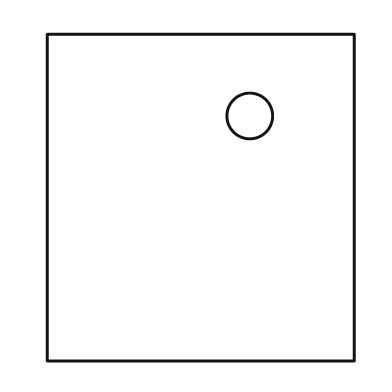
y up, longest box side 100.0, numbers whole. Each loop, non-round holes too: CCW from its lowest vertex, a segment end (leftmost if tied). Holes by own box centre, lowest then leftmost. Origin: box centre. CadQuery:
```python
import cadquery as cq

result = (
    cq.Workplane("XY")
    .moveTo(-47.0, -50.0)
    .lineTo(47.0, -50.0)
    .lineTo(47.0, 50.0)
    .lineTo(-47.0, 50.0)
    .close()
    .moveTo(15.0, 25.0)
    .circle(7.0)
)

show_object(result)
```